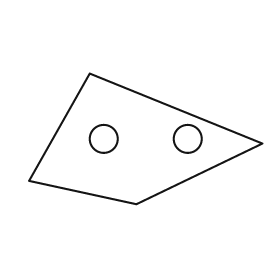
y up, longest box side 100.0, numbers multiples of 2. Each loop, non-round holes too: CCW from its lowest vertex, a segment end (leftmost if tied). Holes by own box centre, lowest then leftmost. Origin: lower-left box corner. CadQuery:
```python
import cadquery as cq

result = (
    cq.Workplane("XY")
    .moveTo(46.0, 0.0)
    .lineTo(100.0, 26.0)
    .lineTo(26.0, 56.0)
    .lineTo(0.0, 10.0)
    .close()
    .moveTo(32.0, 28.0)
    .circle(6.0)
    .moveTo(68.0, 28.0)
    .circle(6.0)
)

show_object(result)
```